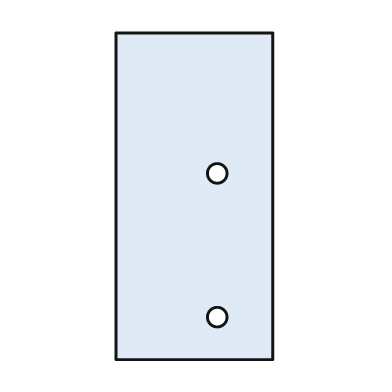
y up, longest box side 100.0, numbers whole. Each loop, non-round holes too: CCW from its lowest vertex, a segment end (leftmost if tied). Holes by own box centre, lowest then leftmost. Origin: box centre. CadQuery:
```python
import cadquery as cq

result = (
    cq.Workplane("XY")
    .moveTo(-24.0, -50.0)
    .lineTo(24.0, -50.0)
    .lineTo(24.0, 50.0)
    .lineTo(-24.0, 50.0)
    .close()
    .moveTo(7.0, -37.0)
    .circle(3.0)
    .moveTo(7.0, 7.0)
    .circle(3.0)
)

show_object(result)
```